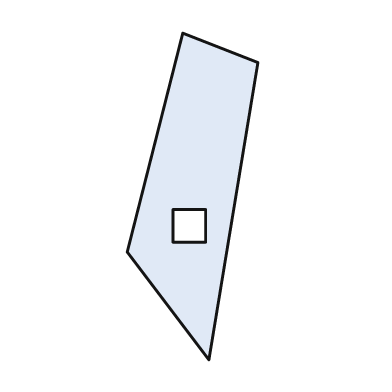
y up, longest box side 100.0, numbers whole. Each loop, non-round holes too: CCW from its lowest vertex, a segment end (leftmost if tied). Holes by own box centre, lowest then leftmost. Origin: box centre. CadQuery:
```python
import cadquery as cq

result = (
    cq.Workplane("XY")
    .moveTo(5.0, -50.0)
    .lineTo(20.0, 41.0)
    .lineTo(-3.0, 50.0)
    .lineTo(-20.0, -17.0)
    .close()
    .moveTo(-6.0, -14.0)
    .lineTo(4.0, -14.0)
    .lineTo(4.0, -4.0)
    .lineTo(-6.0, -4.0)
    .close()
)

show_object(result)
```